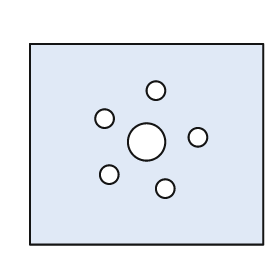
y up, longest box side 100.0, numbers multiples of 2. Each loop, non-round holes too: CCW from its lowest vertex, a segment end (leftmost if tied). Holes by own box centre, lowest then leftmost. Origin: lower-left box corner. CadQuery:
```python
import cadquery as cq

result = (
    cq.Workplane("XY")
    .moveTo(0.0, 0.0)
    .lineTo(100.0, 0.0)
    .lineTo(100.0, 86.0)
    .lineTo(0.0, 86.0)
    .close()
    .moveTo(58.0, 24.0)
    .circle(4.0)
    .moveTo(34.0, 30.0)
    .circle(4.0)
    .moveTo(50.0, 44.0)
    .circle(8.0)
    .moveTo(72.0, 46.0)
    .circle(4.0)
    .moveTo(32.0, 54.0)
    .circle(4.0)
    .moveTo(54.0, 66.0)
    .circle(4.0)
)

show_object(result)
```